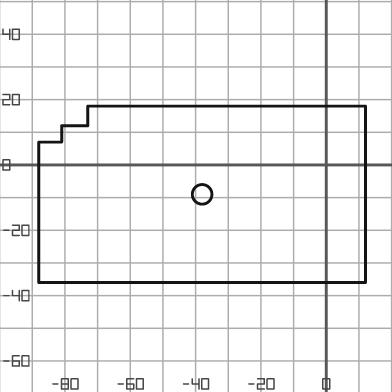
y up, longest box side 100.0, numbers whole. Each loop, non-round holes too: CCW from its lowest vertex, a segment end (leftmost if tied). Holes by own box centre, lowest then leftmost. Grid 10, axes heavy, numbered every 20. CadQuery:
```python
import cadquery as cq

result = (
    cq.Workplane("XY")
    .moveTo(-88.0, -36.0)
    .lineTo(12.0, -36.0)
    .lineTo(12.0, 18.0)
    .lineTo(-73.0, 18.0)
    .lineTo(-73.0, 12.0)
    .lineTo(-81.0, 12.0)
    .lineTo(-81.0, 7.0)
    .lineTo(-88.0, 7.0)
    .close()
    .moveTo(-38.0, -9.0)
    .circle(3.0)
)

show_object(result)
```